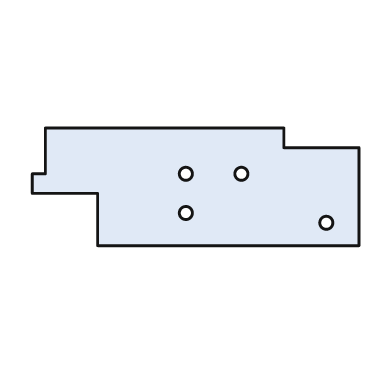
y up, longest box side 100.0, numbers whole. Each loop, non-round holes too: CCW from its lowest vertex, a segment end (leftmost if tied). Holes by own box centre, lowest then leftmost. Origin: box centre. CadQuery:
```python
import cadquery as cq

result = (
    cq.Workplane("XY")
    .moveTo(-30.0, -18.0)
    .lineTo(50.0, -18.0)
    .lineTo(50.0, 12.0)
    .lineTo(27.0, 12.0)
    .lineTo(27.0, 18.0)
    .lineTo(-46.0, 18.0)
    .lineTo(-46.0, 4.0)
    .lineTo(-50.0, 4.0)
    .lineTo(-50.0, -2.0)
    .lineTo(-30.0, -2.0)
    .close()
    .moveTo(40.0, -11.0)
    .circle(2.0)
    .moveTo(-3.0, -8.0)
    .circle(2.0)
    .moveTo(-3.0, 4.0)
    .circle(2.0)
    .moveTo(14.0, 4.0)
    .circle(2.0)
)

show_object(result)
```